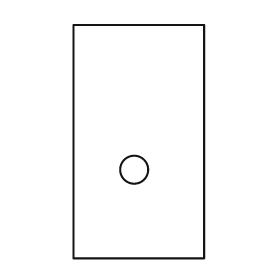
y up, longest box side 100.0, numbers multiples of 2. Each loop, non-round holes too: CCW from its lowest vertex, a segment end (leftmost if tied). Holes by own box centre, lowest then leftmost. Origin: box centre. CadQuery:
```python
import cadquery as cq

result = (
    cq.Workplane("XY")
    .moveTo(-28.0, -50.0)
    .lineTo(28.0, -50.0)
    .lineTo(28.0, 50.0)
    .lineTo(-28.0, 50.0)
    .close()
    .moveTo(-2.0, -12.0)
    .circle(6.0)
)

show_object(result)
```